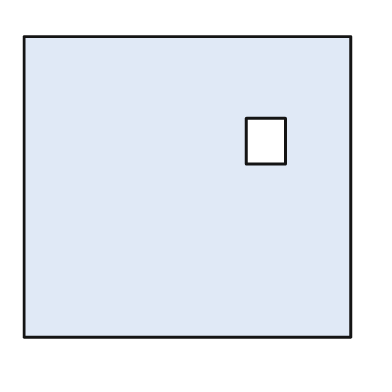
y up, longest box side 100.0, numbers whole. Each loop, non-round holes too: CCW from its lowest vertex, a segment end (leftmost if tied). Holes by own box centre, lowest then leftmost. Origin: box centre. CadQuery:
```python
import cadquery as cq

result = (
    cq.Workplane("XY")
    .moveTo(-50.0, -46.0)
    .lineTo(50.0, -46.0)
    .lineTo(50.0, 46.0)
    .lineTo(-50.0, 46.0)
    .close()
    .moveTo(18.0, 7.0)
    .lineTo(30.0, 7.0)
    .lineTo(30.0, 21.0)
    .lineTo(18.0, 21.0)
    .close()
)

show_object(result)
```